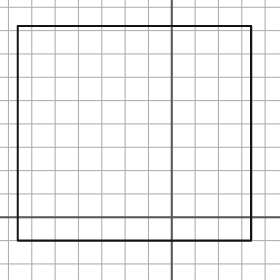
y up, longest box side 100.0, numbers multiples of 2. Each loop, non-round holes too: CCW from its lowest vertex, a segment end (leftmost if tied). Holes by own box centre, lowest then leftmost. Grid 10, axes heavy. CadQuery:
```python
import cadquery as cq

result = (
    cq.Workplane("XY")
    .moveTo(-66.0, -10.0)
    .lineTo(34.0, -10.0)
    .lineTo(34.0, 82.0)
    .lineTo(-66.0, 82.0)
    .close()
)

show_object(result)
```